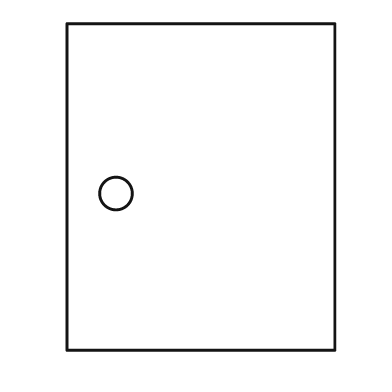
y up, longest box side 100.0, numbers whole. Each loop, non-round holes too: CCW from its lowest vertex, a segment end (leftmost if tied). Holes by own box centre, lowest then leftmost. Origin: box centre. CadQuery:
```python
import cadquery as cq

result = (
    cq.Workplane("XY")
    .moveTo(-41.0, -50.0)
    .lineTo(41.0, -50.0)
    .lineTo(41.0, 50.0)
    .lineTo(-41.0, 50.0)
    .close()
    .moveTo(-26.0, -2.0)
    .circle(5.0)
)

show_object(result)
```